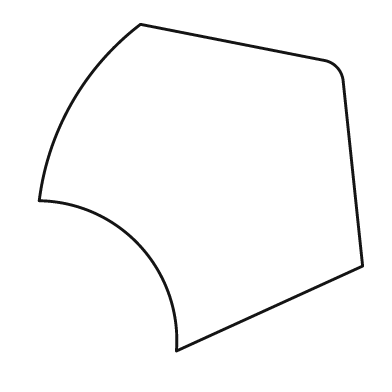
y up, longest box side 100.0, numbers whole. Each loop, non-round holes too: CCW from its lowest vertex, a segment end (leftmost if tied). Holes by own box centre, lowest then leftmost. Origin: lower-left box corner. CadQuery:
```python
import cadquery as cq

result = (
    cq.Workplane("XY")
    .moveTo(42.0, 0.0)
    .lineTo(99.0, 26.0)
    .lineTo(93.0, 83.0)
    .threePointArc((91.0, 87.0), (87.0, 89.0))
    .lineTo(31.0, 100.0)
    .threePointArc((10.0, 76.0), (0.0, 46.0))
    .threePointArc((31.0, 32.0), (42.0, 0.0))
    .close()
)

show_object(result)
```